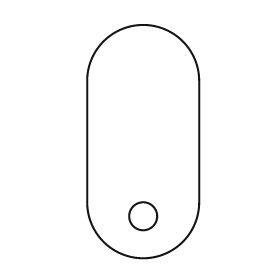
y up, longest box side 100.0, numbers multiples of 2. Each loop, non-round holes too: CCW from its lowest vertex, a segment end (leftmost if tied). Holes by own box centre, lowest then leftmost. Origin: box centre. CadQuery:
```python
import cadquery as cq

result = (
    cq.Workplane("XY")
    .moveTo(-24.0, -26.0)
    .threePointArc((0.0, -50.0), (24.0, -26.0))
    .lineTo(24.0, 26.0)
    .threePointArc((0.0, 50.0), (-24.0, 26.0))
    .close()
    .moveTo(0.0, -32.0)
    .circle(6.0)
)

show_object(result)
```